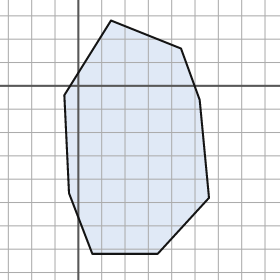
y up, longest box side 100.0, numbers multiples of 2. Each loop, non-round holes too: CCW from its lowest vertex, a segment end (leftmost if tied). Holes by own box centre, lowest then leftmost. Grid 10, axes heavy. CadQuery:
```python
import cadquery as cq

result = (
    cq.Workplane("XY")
    .moveTo(6.0, -72.0)
    .lineTo(34.0, -72.0)
    .lineTo(56.0, -48.0)
    .lineTo(52.0, -6.0)
    .lineTo(44.0, 16.0)
    .lineTo(14.0, 28.0)
    .lineTo(-6.0, -4.0)
    .lineTo(-4.0, -46.0)
    .close()
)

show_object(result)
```